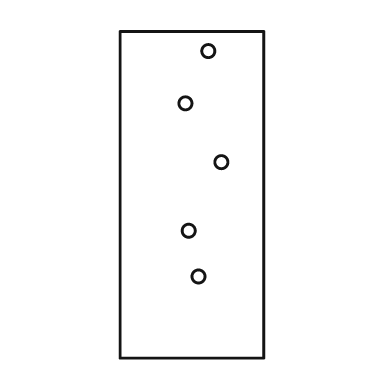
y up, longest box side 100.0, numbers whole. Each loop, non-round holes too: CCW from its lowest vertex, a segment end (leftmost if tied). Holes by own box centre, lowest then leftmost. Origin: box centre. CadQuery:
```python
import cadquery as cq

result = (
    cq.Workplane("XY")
    .moveTo(-22.0, -50.0)
    .lineTo(22.0, -50.0)
    .lineTo(22.0, 50.0)
    .lineTo(-22.0, 50.0)
    .close()
    .moveTo(2.0, -25.0)
    .circle(2.0)
    .moveTo(-1.0, -11.0)
    .circle(2.0)
    .moveTo(9.0, 10.0)
    .circle(2.0)
    .moveTo(-2.0, 28.0)
    .circle(2.0)
    .moveTo(5.0, 44.0)
    .circle(2.0)
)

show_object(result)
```